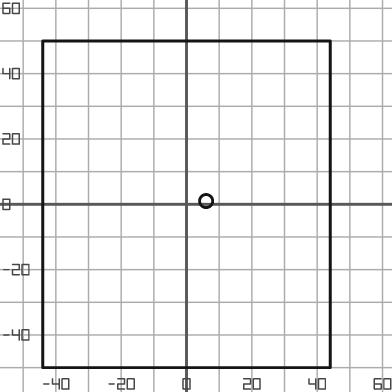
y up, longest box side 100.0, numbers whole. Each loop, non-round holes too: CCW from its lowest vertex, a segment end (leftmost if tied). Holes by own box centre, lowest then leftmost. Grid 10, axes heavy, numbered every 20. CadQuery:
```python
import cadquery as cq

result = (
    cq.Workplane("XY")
    .moveTo(-44.0, -50.0)
    .lineTo(44.0, -50.0)
    .lineTo(44.0, 50.0)
    .lineTo(-44.0, 50.0)
    .close()
    .moveTo(6.0, 1.0)
    .circle(2.0)
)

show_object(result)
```